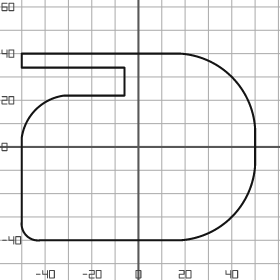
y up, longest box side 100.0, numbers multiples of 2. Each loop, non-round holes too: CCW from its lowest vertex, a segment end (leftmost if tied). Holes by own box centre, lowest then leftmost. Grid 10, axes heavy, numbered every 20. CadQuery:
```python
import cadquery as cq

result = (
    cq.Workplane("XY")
    .moveTo(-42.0, -40.0)
    .lineTo(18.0, -40.0)
    .threePointArc((40.0, -30.0), (50.0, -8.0))
    .lineTo(50.0, 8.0)
    .threePointArc((40.0, 30.0), (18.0, 40.0))
    .lineTo(-50.0, 40.0)
    .lineTo(-50.0, 34.0)
    .lineTo(-6.0, 34.0)
    .lineTo(-6.0, 22.0)
    .lineTo(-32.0, 22.0)
    .threePointArc((-44.0, 16.0), (-50.0, 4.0))
    .lineTo(-50.0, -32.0)
    .threePointArc((-48.0, -38.0), (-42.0, -40.0))
    .close()
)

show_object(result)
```